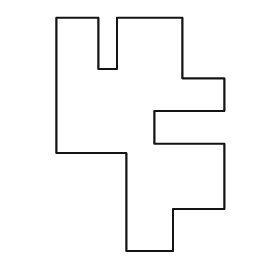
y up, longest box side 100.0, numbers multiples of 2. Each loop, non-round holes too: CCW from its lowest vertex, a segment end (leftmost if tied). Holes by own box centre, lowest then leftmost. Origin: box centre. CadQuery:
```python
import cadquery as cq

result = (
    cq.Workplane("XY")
    .moveTo(-6.0, -50.0)
    .lineTo(14.0, -50.0)
    .lineTo(14.0, -32.0)
    .lineTo(36.0, -32.0)
    .lineTo(36.0, -4.0)
    .lineTo(6.0, -4.0)
    .lineTo(6.0, 10.0)
    .lineTo(36.0, 10.0)
    .lineTo(36.0, 24.0)
    .lineTo(18.0, 24.0)
    .lineTo(18.0, 50.0)
    .lineTo(-10.0, 50.0)
    .lineTo(-10.0, 28.0)
    .lineTo(-18.0, 28.0)
    .lineTo(-18.0, 50.0)
    .lineTo(-36.0, 50.0)
    .lineTo(-36.0, -8.0)
    .lineTo(-6.0, -8.0)
    .close()
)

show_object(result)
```